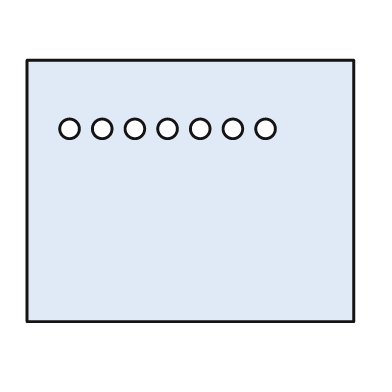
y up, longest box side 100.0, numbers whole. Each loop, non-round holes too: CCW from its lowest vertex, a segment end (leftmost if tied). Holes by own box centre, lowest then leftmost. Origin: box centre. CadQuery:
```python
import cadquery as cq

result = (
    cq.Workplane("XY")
    .moveTo(-50.0, -40.0)
    .lineTo(50.0, -40.0)
    .lineTo(50.0, 40.0)
    .lineTo(-50.0, 40.0)
    .close()
    .moveTo(-37.0, 19.0)
    .circle(3.0)
    .moveTo(-27.0, 19.0)
    .circle(3.0)
    .moveTo(-17.0, 19.0)
    .circle(3.0)
    .moveTo(-7.0, 19.0)
    .circle(3.0)
    .moveTo(3.0, 19.0)
    .circle(3.0)
    .moveTo(13.0, 19.0)
    .circle(3.0)
    .moveTo(23.0, 19.0)
    .circle(3.0)
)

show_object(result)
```